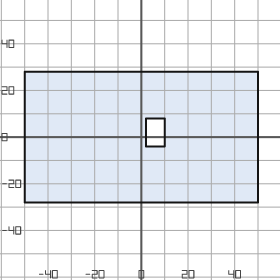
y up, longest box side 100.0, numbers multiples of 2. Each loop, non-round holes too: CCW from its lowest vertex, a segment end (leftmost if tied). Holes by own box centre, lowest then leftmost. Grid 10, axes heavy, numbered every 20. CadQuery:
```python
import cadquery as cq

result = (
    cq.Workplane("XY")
    .moveTo(-50.0, -28.0)
    .lineTo(50.0, -28.0)
    .lineTo(50.0, 28.0)
    .lineTo(-50.0, 28.0)
    .close()
    .moveTo(2.0, -4.0)
    .lineTo(10.0, -4.0)
    .lineTo(10.0, 8.0)
    .lineTo(2.0, 8.0)
    .close()
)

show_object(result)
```